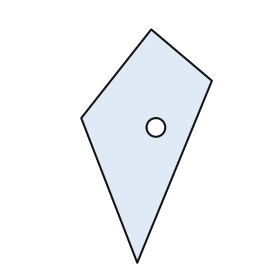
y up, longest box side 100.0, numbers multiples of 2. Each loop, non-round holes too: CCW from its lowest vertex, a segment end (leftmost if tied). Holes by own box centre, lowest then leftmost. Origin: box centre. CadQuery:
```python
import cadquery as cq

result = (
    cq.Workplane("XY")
    .moveTo(-4.0, -50.0)
    .lineTo(28.0, 28.0)
    .lineTo(2.0, 50.0)
    .lineTo(-28.0, 12.0)
    .close()
    .moveTo(4.0, 8.0)
    .circle(4.0)
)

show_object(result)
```